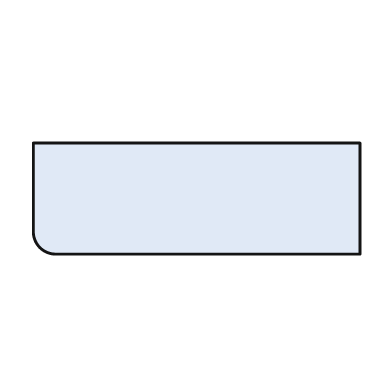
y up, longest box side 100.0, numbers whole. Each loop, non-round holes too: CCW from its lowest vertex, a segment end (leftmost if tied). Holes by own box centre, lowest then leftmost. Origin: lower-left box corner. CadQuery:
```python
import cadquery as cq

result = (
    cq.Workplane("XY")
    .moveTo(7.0, 0.0)
    .lineTo(100.0, 0.0)
    .lineTo(100.0, 34.0)
    .lineTo(0.0, 34.0)
    .lineTo(0.0, 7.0)
    .threePointArc((2.0, 2.0), (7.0, 0.0))
    .close()
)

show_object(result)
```